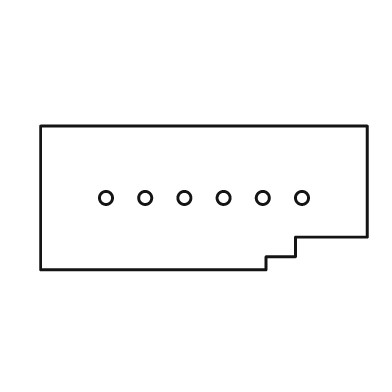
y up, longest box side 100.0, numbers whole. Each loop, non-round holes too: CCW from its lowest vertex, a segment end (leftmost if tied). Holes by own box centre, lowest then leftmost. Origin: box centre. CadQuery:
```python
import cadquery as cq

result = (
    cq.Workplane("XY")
    .moveTo(-50.0, -22.0)
    .lineTo(19.0, -22.0)
    .lineTo(19.0, -18.0)
    .lineTo(28.0, -18.0)
    .lineTo(28.0, -12.0)
    .lineTo(50.0, -12.0)
    .lineTo(50.0, 22.0)
    .lineTo(-50.0, 22.0)
    .close()
    .moveTo(-30.0, 0.0)
    .circle(2.0)
    .moveTo(-18.0, 0.0)
    .circle(2.0)
    .moveTo(-6.0, 0.0)
    .circle(2.0)
    .moveTo(6.0, 0.0)
    .circle(2.0)
    .moveTo(18.0, 0.0)
    .circle(2.0)
    .moveTo(30.0, 0.0)
    .circle(2.0)
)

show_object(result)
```